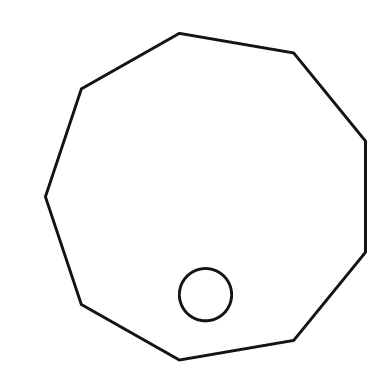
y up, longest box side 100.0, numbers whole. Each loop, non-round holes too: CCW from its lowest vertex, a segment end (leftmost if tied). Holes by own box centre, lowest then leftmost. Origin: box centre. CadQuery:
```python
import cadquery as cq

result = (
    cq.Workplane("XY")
    .moveTo(-8.0, -50.0)
    .lineTo(27.0, -44.0)
    .lineTo(49.0, -17.0)
    .lineTo(49.0, 17.0)
    .lineTo(27.0, 44.0)
    .lineTo(-8.0, 50.0)
    .lineTo(-38.0, 33.0)
    .lineTo(-49.0, 0.0)
    .lineTo(-38.0, -33.0)
    .close()
    .moveTo(0.0, -30.0)
    .circle(8.0)
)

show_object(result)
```